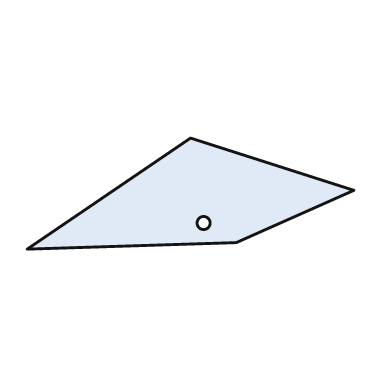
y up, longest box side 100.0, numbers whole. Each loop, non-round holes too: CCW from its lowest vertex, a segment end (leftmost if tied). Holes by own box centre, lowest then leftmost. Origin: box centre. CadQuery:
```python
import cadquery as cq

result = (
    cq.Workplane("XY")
    .moveTo(-50.0, -17.0)
    .lineTo(14.0, -15.0)
    .lineTo(50.0, 1.0)
    .lineTo(0.0, 17.0)
    .close()
    .moveTo(4.0, -9.0)
    .circle(2.0)
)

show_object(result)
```